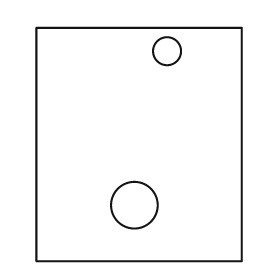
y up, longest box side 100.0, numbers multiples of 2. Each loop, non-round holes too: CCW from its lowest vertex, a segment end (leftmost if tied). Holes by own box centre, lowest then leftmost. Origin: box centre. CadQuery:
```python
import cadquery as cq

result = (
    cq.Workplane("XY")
    .moveTo(-44.0, -50.0)
    .lineTo(44.0, -50.0)
    .lineTo(44.0, 50.0)
    .lineTo(-44.0, 50.0)
    .close()
    .moveTo(-2.0, -26.0)
    .circle(10.0)
    .moveTo(12.0, 40.0)
    .circle(6.0)
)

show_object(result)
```